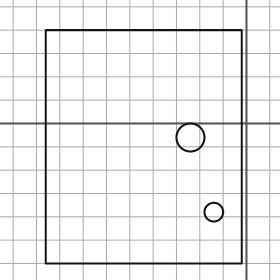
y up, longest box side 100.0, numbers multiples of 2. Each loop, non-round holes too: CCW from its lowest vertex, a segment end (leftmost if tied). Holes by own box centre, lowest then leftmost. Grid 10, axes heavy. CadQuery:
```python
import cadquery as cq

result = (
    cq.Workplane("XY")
    .moveTo(-86.0, -60.0)
    .lineTo(-2.0, -60.0)
    .lineTo(-2.0, 40.0)
    .lineTo(-86.0, 40.0)
    .close()
    .moveTo(-14.0, -38.0)
    .circle(4.0)
    .moveTo(-24.0, -6.0)
    .circle(6.0)
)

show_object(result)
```